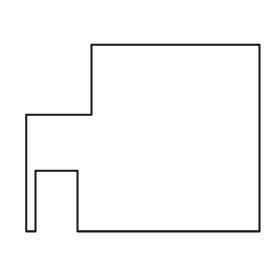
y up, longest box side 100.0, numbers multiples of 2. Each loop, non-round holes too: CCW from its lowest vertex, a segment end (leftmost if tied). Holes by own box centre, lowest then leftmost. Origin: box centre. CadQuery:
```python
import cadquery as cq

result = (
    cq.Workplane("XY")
    .moveTo(-50.0, -40.0)
    .lineTo(-46.0, -40.0)
    .lineTo(-46.0, -14.0)
    .lineTo(-28.0, -14.0)
    .lineTo(-28.0, -40.0)
    .lineTo(50.0, -40.0)
    .lineTo(50.0, 40.0)
    .lineTo(-22.0, 40.0)
    .lineTo(-22.0, 10.0)
    .lineTo(-50.0, 10.0)
    .close()
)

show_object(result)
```